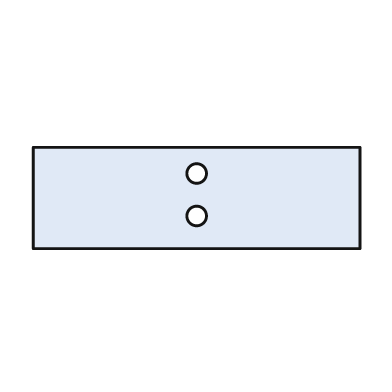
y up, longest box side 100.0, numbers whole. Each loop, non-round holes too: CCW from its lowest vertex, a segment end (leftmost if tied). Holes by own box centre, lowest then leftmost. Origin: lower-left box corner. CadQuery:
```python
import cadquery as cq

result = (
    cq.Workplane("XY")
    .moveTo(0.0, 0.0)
    .lineTo(100.0, 0.0)
    .lineTo(100.0, 31.0)
    .lineTo(0.0, 31.0)
    .close()
    .moveTo(50.0, 10.0)
    .circle(3.0)
    .moveTo(50.0, 23.0)
    .circle(3.0)
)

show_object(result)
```